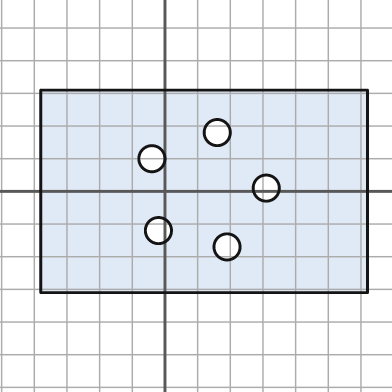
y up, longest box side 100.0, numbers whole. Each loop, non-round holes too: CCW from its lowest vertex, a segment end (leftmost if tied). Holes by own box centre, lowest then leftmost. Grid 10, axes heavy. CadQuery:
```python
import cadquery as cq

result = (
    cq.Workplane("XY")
    .moveTo(-38.0, -31.0)
    .lineTo(62.0, -31.0)
    .lineTo(62.0, 31.0)
    .lineTo(-38.0, 31.0)
    .close()
    .moveTo(19.0, -17.0)
    .circle(4.0)
    .moveTo(-2.0, -12.0)
    .circle(4.0)
    .moveTo(31.0, 1.0)
    .circle(4.0)
    .moveTo(-4.0, 10.0)
    .circle(4.0)
    .moveTo(16.0, 18.0)
    .circle(4.0)
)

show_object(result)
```